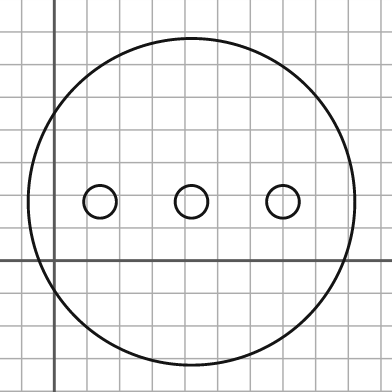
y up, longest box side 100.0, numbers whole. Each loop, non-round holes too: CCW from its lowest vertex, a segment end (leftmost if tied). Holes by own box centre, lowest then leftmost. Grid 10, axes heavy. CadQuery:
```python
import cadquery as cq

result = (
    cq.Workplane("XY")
    .moveTo(42.0, 18.0)
    .circle(50.0)
    .moveTo(14.0, 18.0)
    .circle(5.0)
    .moveTo(42.0, 18.0)
    .circle(5.0)
    .moveTo(70.0, 18.0)
    .circle(5.0)
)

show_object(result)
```